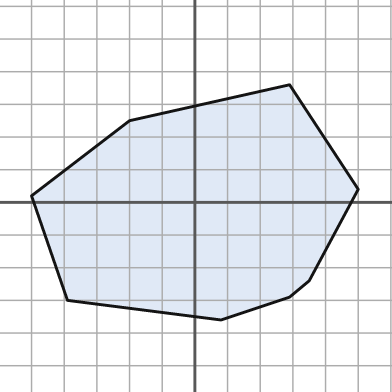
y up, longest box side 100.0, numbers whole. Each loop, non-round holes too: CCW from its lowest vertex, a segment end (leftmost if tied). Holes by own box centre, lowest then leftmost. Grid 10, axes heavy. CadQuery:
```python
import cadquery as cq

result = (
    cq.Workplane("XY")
    .moveTo(8.0, -36.0)
    .lineTo(29.0, -29.0)
    .lineTo(35.0, -24.0)
    .lineTo(50.0, 4.0)
    .lineTo(29.0, 36.0)
    .lineTo(-20.0, 25.0)
    .lineTo(-50.0, 2.0)
    .lineTo(-39.0, -30.0)
    .close()
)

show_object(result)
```